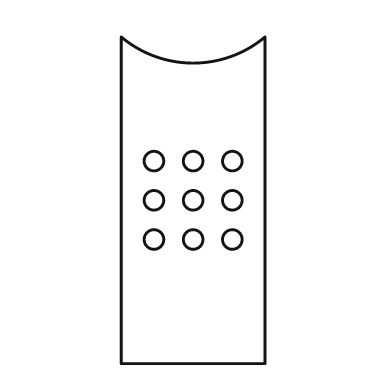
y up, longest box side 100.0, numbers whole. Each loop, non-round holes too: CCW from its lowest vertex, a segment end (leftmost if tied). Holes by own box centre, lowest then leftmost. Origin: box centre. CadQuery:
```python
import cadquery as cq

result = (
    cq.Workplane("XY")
    .moveTo(-22.0, -50.0)
    .lineTo(22.0, -50.0)
    .lineTo(22.0, 50.0)
    .threePointArc((0.0, 42.0), (-22.0, 50.0))
    .close()
    .moveTo(-12.0, -12.0)
    .circle(3.0)
    .moveTo(0.0, -12.0)
    .circle(3.0)
    .moveTo(12.0, -12.0)
    .circle(3.0)
    .moveTo(-12.0, 0.0)
    .circle(3.0)
    .moveTo(0.0, 0.0)
    .circle(3.0)
    .moveTo(12.0, 0.0)
    .circle(3.0)
    .moveTo(-12.0, 12.0)
    .circle(3.0)
    .moveTo(0.0, 12.0)
    .circle(3.0)
    .moveTo(12.0, 12.0)
    .circle(3.0)
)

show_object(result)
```